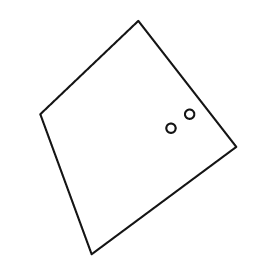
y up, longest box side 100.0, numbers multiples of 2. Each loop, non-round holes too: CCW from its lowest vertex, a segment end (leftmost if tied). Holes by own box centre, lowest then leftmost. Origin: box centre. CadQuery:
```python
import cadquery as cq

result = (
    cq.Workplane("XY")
    .moveTo(-20.0, -50.0)
    .lineTo(42.0, -4.0)
    .lineTo(0.0, 50.0)
    .lineTo(-42.0, 10.0)
    .close()
    .moveTo(14.0, 4.0)
    .circle(2.0)
    .moveTo(22.0, 10.0)
    .circle(2.0)
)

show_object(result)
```